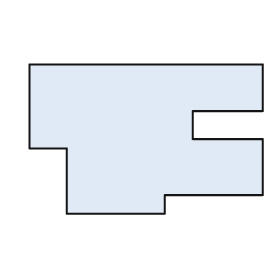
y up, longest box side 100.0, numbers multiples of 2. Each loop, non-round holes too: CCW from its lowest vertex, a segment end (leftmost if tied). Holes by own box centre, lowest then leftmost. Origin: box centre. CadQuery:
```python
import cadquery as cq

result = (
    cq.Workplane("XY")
    .moveTo(-34.0, -32.0)
    .lineTo(8.0, -32.0)
    .lineTo(8.0, -24.0)
    .lineTo(50.0, -24.0)
    .lineTo(50.0, 0.0)
    .lineTo(20.0, 0.0)
    .lineTo(20.0, 12.0)
    .lineTo(50.0, 12.0)
    .lineTo(50.0, 32.0)
    .lineTo(-50.0, 32.0)
    .lineTo(-50.0, -4.0)
    .lineTo(-34.0, -4.0)
    .close()
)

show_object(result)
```